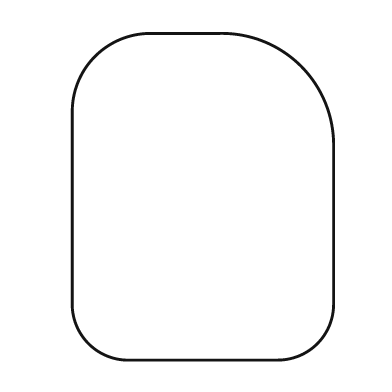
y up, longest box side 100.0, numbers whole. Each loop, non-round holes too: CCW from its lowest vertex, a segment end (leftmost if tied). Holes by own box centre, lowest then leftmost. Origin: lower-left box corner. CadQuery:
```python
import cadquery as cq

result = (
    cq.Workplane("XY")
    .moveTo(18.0, 0.0)
    .lineTo(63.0, 0.0)
    .threePointArc((75.0, 5.0), (80.0, 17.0))
    .lineTo(80.0, 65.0)
    .threePointArc((70.0, 90.0), (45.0, 100.0))
    .lineTo(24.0, 100.0)
    .threePointArc((7.0, 93.0), (0.0, 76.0))
    .lineTo(0.0, 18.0)
    .threePointArc((5.0, 5.0), (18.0, 0.0))
    .close()
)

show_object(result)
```